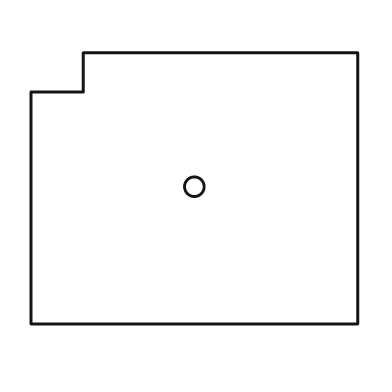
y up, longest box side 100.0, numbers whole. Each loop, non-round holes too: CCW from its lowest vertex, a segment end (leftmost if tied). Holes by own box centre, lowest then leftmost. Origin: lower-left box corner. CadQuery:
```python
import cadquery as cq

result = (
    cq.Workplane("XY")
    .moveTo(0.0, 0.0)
    .lineTo(100.0, 0.0)
    .lineTo(100.0, 83.0)
    .lineTo(16.0, 83.0)
    .lineTo(16.0, 71.0)
    .lineTo(0.0, 71.0)
    .close()
    .moveTo(50.0, 42.0)
    .circle(3.0)
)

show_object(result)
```